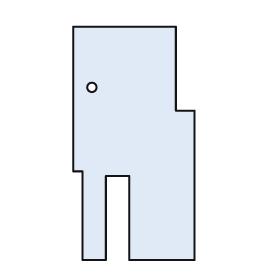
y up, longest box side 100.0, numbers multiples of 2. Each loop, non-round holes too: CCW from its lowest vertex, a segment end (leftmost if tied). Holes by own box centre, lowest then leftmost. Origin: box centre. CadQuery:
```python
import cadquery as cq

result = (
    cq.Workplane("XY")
    .moveTo(-22.0, -50.0)
    .lineTo(-12.0, -50.0)
    .lineTo(-12.0, -14.0)
    .lineTo(-2.0, -14.0)
    .lineTo(-2.0, -50.0)
    .lineTo(26.0, -50.0)
    .lineTo(26.0, 14.0)
    .lineTo(18.0, 14.0)
    .lineTo(18.0, 50.0)
    .lineTo(-26.0, 50.0)
    .lineTo(-26.0, -12.0)
    .lineTo(-22.0, -12.0)
    .close()
    .moveTo(-18.0, 24.0)
    .circle(2.0)
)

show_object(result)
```